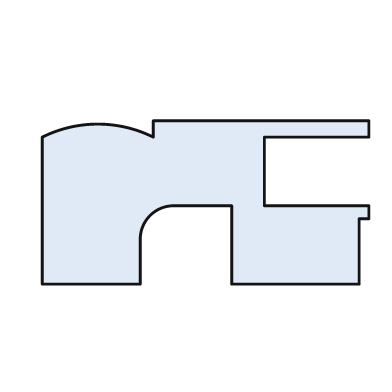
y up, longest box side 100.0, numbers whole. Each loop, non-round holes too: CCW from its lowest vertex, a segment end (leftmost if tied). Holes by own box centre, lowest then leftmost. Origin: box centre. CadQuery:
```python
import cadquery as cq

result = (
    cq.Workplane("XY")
    .moveTo(-50.0, -25.0)
    .lineTo(-20.0, -25.0)
    .lineTo(-20.0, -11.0)
    .threePointArc((-17.0, -4.0), (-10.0, -1.0))
    .lineTo(8.0, -1.0)
    .lineTo(8.0, -25.0)
    .lineTo(47.0, -25.0)
    .lineTo(47.0, -5.0)
    .lineTo(50.0, -5.0)
    .lineTo(50.0, -1.0)
    .lineTo(18.0, -1.0)
    .lineTo(18.0, 20.0)
    .lineTo(50.0, 20.0)
    .lineTo(50.0, 25.0)
    .lineTo(-16.0, 25.0)
    .lineTo(-16.0, 20.0)
    .threePointArc((-33.0, 24.0), (-50.0, 20.0))
    .close()
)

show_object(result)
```